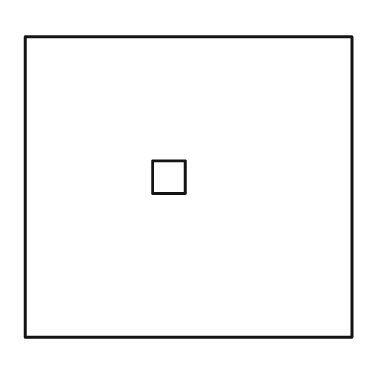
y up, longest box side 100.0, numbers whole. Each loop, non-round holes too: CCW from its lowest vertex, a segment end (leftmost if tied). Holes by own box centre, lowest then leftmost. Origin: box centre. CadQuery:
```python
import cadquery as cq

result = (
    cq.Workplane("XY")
    .moveTo(-50.0, -46.0)
    .lineTo(50.0, -46.0)
    .lineTo(50.0, 46.0)
    .lineTo(-50.0, 46.0)
    .close()
    .moveTo(-11.0, -2.0)
    .lineTo(-1.0, -2.0)
    .lineTo(-1.0, 8.0)
    .lineTo(-11.0, 8.0)
    .close()
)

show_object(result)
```